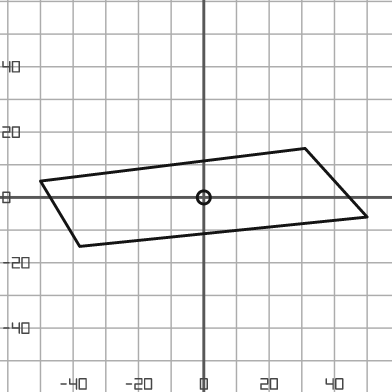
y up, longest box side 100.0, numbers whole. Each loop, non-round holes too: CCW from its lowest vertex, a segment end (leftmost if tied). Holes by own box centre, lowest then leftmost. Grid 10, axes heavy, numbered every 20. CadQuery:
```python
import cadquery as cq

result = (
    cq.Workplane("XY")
    .moveTo(-38.0, -15.0)
    .lineTo(50.0, -6.0)
    .lineTo(31.0, 15.0)
    .lineTo(-50.0, 5.0)
    .close()
    .moveTo(0.0, 0.0)
    .circle(2.0)
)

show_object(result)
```